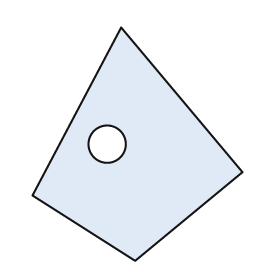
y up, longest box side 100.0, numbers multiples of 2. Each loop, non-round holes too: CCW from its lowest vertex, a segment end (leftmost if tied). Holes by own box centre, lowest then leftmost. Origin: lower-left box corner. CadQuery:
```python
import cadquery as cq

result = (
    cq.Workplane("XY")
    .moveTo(44.0, 0.0)
    .lineTo(90.0, 38.0)
    .lineTo(38.0, 100.0)
    .lineTo(0.0, 28.0)
    .close()
    .moveTo(32.0, 50.0)
    .circle(8.0)
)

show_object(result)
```